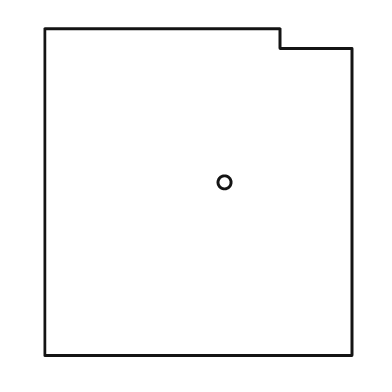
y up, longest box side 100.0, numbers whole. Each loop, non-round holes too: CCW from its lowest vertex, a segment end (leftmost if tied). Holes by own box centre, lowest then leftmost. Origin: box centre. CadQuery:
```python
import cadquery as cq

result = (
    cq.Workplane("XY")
    .moveTo(-47.0, -50.0)
    .lineTo(47.0, -50.0)
    .lineTo(47.0, 44.0)
    .lineTo(25.0, 44.0)
    .lineTo(25.0, 50.0)
    .lineTo(-47.0, 50.0)
    .close()
    .moveTo(8.0, 3.0)
    .circle(2.0)
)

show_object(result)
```